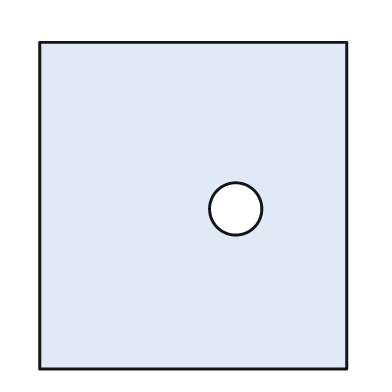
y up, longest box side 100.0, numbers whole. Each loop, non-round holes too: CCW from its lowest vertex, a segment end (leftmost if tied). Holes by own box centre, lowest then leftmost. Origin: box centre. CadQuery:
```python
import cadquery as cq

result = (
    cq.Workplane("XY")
    .moveTo(-47.0, -50.0)
    .lineTo(47.0, -50.0)
    .lineTo(47.0, 50.0)
    .lineTo(-47.0, 50.0)
    .close()
    .moveTo(13.0, -1.0)
    .circle(8.0)
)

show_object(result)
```